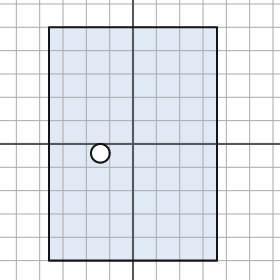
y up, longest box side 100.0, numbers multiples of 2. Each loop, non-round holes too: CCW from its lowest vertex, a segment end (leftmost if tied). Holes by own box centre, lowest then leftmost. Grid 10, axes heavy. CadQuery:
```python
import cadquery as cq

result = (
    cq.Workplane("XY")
    .moveTo(-36.0, -50.0)
    .lineTo(36.0, -50.0)
    .lineTo(36.0, 50.0)
    .lineTo(-36.0, 50.0)
    .close()
    .moveTo(-14.0, -4.0)
    .circle(4.0)
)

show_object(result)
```